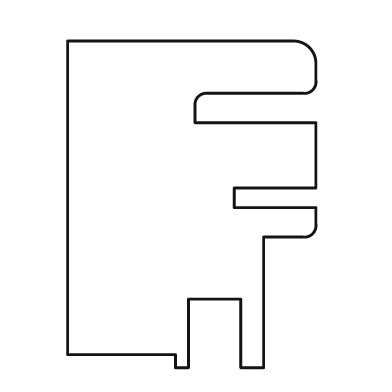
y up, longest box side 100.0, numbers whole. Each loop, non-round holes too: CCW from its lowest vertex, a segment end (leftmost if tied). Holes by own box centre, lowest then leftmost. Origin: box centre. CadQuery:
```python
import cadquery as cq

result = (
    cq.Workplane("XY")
    .moveTo(-5.0, -50.0)
    .lineTo(-1.0, -50.0)
    .lineTo(-1.0, -29.0)
    .lineTo(15.0, -29.0)
    .lineTo(15.0, -50.0)
    .lineTo(22.0, -50.0)
    .lineTo(22.0, -10.0)
    .lineTo(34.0, -10.0)
    .threePointArc((37.0, -9.0), (38.0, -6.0))
    .lineTo(38.0, -1.0)
    .lineTo(13.0, -1.0)
    .lineTo(13.0, 5.0)
    .lineTo(38.0, 5.0)
    .lineTo(38.0, 25.0)
    .lineTo(1.0, 25.0)
    .lineTo(1.0, 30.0)
    .threePointArc((2.0, 33.0), (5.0, 34.0))
    .lineTo(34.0, 34.0)
    .threePointArc((37.0, 35.0), (38.0, 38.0))
    .lineTo(38.0, 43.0)
    .threePointArc((36.0, 48.0), (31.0, 50.0))
    .lineTo(-38.0, 50.0)
    .lineTo(-38.0, -46.0)
    .lineTo(-5.0, -46.0)
    .close()
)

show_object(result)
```